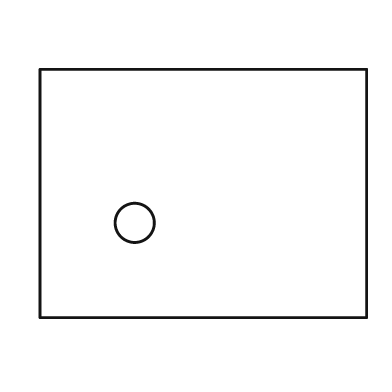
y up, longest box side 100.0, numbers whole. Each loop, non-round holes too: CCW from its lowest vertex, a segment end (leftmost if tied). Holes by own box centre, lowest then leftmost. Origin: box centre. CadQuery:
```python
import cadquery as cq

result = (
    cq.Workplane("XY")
    .moveTo(-50.0, -38.0)
    .lineTo(50.0, -38.0)
    .lineTo(50.0, 38.0)
    .lineTo(-50.0, 38.0)
    .close()
    .moveTo(-21.0, -9.0)
    .circle(6.0)
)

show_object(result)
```